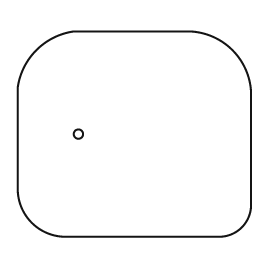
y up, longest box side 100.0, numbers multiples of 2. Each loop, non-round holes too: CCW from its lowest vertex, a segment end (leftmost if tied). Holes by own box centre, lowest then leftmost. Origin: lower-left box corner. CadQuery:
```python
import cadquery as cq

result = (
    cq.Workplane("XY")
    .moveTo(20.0, 0.0)
    .lineTo(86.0, 0.0)
    .threePointArc((96.0, 4.0), (100.0, 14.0))
    .lineTo(100.0, 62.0)
    .threePointArc((92.0, 80.0), (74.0, 88.0))
    .lineTo(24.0, 88.0)
    .threePointArc((8.0, 80.0), (0.0, 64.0))
    .lineTo(0.0, 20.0)
    .threePointArc((6.0, 6.0), (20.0, 0.0))
    .close()
    .moveTo(26.0, 44.0)
    .circle(2.0)
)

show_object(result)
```